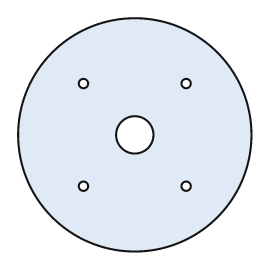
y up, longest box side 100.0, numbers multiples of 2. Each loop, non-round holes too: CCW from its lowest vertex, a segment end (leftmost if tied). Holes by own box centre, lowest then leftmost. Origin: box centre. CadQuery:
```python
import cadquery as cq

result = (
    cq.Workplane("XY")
    .moveTo(0.0, 0.0)
    .circle(50.0)
    .moveTo(-22.0, -22.0)
    .circle(2.0)
    .moveTo(22.0, -22.0)
    .circle(2.0)
    .moveTo(0.0, 0.0)
    .circle(8.0)
    .moveTo(-22.0, 22.0)
    .circle(2.0)
    .moveTo(22.0, 22.0)
    .circle(2.0)
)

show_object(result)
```